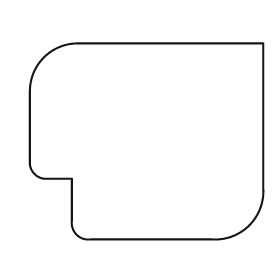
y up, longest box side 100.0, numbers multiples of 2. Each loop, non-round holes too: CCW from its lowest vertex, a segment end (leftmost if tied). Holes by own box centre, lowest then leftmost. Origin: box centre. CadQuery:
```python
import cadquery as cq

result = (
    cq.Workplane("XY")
    .moveTo(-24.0, -42.0)
    .lineTo(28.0, -42.0)
    .threePointArc((44.0, -36.0), (50.0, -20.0))
    .lineTo(50.0, 42.0)
    .lineTo(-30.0, 42.0)
    .threePointArc((-44.0, 36.0), (-50.0, 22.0))
    .lineTo(-50.0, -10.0)
    .threePointArc((-48.0, -14.0), (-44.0, -16.0))
    .lineTo(-32.0, -16.0)
    .lineTo(-32.0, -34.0)
    .threePointArc((-30.0, -40.0), (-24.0, -42.0))
    .close()
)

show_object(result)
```